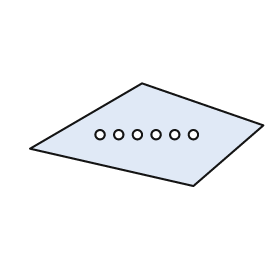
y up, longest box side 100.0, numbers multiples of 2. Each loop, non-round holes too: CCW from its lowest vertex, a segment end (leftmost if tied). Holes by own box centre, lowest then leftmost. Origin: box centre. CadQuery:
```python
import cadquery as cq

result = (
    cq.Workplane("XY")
    .moveTo(20.0, -22.0)
    .lineTo(50.0, 4.0)
    .lineTo(-2.0, 22.0)
    .lineTo(-50.0, -6.0)
    .close()
    .moveTo(-20.0, 0.0)
    .circle(2.0)
    .moveTo(-12.0, 0.0)
    .circle(2.0)
    .moveTo(-4.0, 0.0)
    .circle(2.0)
    .moveTo(4.0, 0.0)
    .circle(2.0)
    .moveTo(12.0, 0.0)
    .circle(2.0)
    .moveTo(20.0, 0.0)
    .circle(2.0)
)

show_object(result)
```